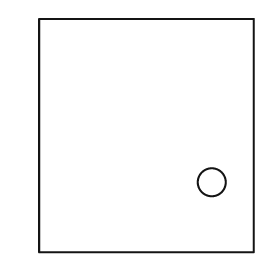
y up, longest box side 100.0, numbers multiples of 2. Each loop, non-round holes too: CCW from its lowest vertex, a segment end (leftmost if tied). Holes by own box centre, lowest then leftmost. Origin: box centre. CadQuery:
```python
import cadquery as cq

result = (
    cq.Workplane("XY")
    .moveTo(-46.0, -50.0)
    .lineTo(46.0, -50.0)
    .lineTo(46.0, 50.0)
    .lineTo(-46.0, 50.0)
    .close()
    .moveTo(28.0, -20.0)
    .circle(6.0)
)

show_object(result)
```